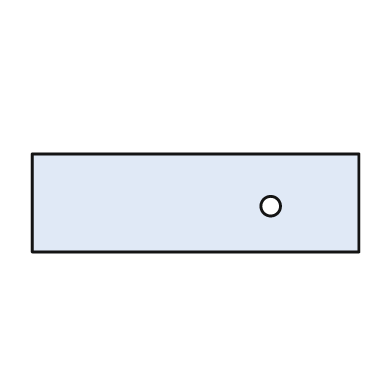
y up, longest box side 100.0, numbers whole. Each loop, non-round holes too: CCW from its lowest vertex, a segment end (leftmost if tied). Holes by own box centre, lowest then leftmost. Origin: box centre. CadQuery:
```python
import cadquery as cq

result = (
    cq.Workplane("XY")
    .moveTo(-50.0, -15.0)
    .lineTo(50.0, -15.0)
    .lineTo(50.0, 15.0)
    .lineTo(-50.0, 15.0)
    .close()
    .moveTo(23.0, -1.0)
    .circle(3.0)
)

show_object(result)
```